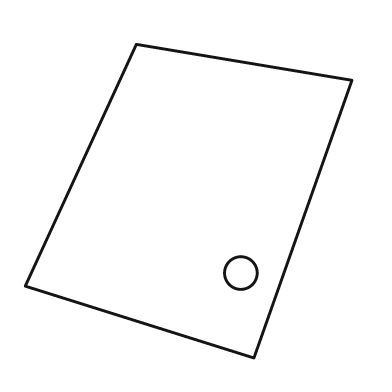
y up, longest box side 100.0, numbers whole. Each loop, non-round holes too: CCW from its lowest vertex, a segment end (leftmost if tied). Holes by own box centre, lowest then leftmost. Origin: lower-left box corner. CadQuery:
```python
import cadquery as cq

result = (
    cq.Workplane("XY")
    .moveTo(70.0, 0.0)
    .lineTo(100.0, 85.0)
    .lineTo(34.0, 96.0)
    .lineTo(0.0, 22.0)
    .close()
    .moveTo(66.0, 26.0)
    .circle(5.0)
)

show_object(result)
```